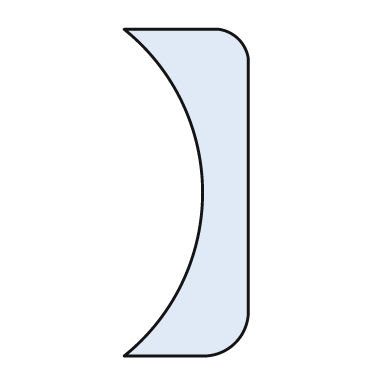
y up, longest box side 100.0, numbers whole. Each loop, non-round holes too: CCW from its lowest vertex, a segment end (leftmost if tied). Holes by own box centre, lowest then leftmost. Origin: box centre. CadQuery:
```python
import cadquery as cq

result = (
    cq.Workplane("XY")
    .moveTo(-19.0, -50.0)
    .lineTo(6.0, -50.0)
    .threePointArc((15.0, -46.0), (19.0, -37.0))
    .lineTo(19.0, 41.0)
    .threePointArc((16.0, 47.0), (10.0, 50.0))
    .lineTo(-19.0, 50.0)
    .threePointArc((5.0, 0.0), (-19.0, -50.0))
    .close()
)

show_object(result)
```